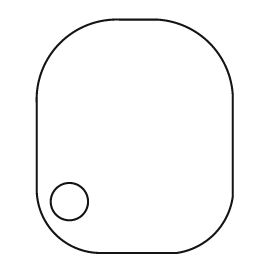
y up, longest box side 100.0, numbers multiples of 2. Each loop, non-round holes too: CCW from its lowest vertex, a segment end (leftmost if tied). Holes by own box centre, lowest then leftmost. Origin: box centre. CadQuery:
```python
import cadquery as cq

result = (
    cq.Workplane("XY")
    .moveTo(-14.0, -50.0)
    .lineTo(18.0, -50.0)
    .threePointArc((34.0, -42.0), (42.0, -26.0))
    .lineTo(42.0, 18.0)
    .threePointArc((32.0, 40.0), (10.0, 50.0))
    .lineTo(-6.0, 50.0)
    .threePointArc((-32.0, 40.0), (-42.0, 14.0))
    .lineTo(-42.0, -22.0)
    .threePointArc((-34.0, -42.0), (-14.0, -50.0))
    .close()
    .moveTo(-28.0, -28.0)
    .circle(8.0)
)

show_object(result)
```